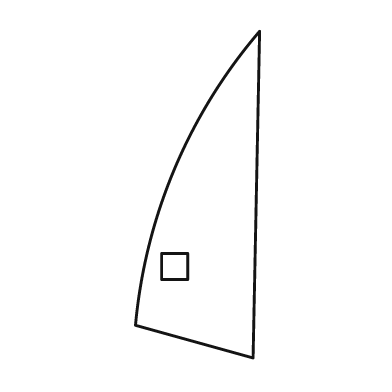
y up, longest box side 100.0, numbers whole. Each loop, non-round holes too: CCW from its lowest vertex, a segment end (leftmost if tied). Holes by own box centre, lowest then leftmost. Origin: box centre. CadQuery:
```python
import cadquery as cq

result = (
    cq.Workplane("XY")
    .moveTo(17.0, -50.0)
    .lineTo(19.0, 50.0)
    .threePointArc((-7.0, 8.0), (-19.0, -40.0))
    .close()
    .moveTo(-11.0, -26.0)
    .lineTo(-3.0, -26.0)
    .lineTo(-3.0, -18.0)
    .lineTo(-11.0, -18.0)
    .close()
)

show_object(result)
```